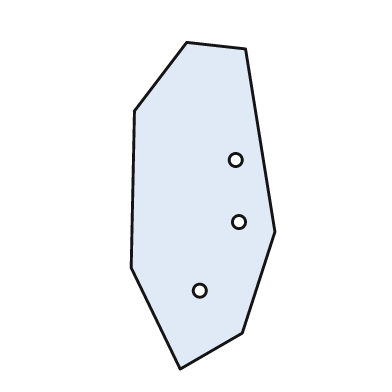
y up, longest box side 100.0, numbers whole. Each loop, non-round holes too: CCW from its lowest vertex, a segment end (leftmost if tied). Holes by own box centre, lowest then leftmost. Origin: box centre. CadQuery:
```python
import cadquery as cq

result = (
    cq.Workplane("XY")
    .moveTo(-7.0, -50.0)
    .lineTo(12.0, -39.0)
    .lineTo(22.0, -8.0)
    .lineTo(13.0, 48.0)
    .lineTo(-5.0, 50.0)
    .lineTo(-21.0, 29.0)
    .lineTo(-22.0, -19.0)
    .close()
    .moveTo(-1.0, -26.0)
    .circle(2.0)
    .moveTo(11.0, -5.0)
    .circle(2.0)
    .moveTo(10.0, 14.0)
    .circle(2.0)
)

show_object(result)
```